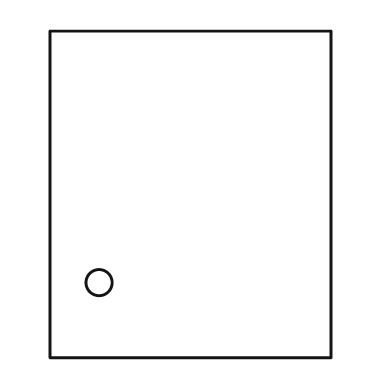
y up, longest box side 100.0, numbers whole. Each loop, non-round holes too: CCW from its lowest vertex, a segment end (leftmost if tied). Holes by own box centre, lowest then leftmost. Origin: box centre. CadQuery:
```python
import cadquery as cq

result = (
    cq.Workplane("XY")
    .moveTo(-43.0, -50.0)
    .lineTo(43.0, -50.0)
    .lineTo(43.0, 50.0)
    .lineTo(-43.0, 50.0)
    .close()
    .moveTo(-28.0, -27.0)
    .circle(4.0)
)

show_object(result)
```